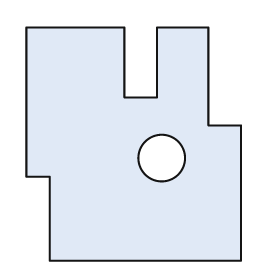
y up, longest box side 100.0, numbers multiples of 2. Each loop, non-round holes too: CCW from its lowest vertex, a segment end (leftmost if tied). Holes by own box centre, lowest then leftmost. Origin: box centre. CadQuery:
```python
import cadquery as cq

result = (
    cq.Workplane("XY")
    .moveTo(-36.0, -50.0)
    .lineTo(46.0, -50.0)
    .lineTo(46.0, 8.0)
    .lineTo(32.0, 8.0)
    .lineTo(32.0, 50.0)
    .lineTo(10.0, 50.0)
    .lineTo(10.0, 20.0)
    .lineTo(-4.0, 20.0)
    .lineTo(-4.0, 50.0)
    .lineTo(-46.0, 50.0)
    .lineTo(-46.0, -14.0)
    .lineTo(-36.0, -14.0)
    .close()
    .moveTo(12.0, -6.0)
    .circle(10.0)
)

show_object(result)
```